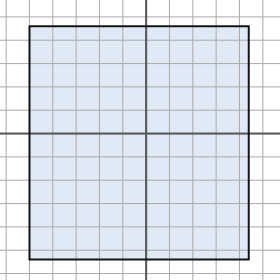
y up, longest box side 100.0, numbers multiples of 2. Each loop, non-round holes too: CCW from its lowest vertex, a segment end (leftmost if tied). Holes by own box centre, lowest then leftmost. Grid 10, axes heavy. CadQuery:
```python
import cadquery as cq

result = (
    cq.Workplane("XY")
    .moveTo(-50.0, -54.0)
    .lineTo(44.0, -54.0)
    .lineTo(44.0, 46.0)
    .lineTo(-50.0, 46.0)
    .close()
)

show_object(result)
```